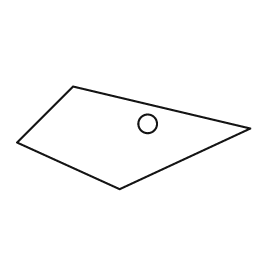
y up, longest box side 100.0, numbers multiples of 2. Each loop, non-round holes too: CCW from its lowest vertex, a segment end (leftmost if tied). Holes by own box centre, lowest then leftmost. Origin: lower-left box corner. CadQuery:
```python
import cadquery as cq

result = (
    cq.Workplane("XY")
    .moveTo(44.0, 0.0)
    .lineTo(100.0, 26.0)
    .lineTo(24.0, 44.0)
    .lineTo(0.0, 20.0)
    .close()
    .moveTo(56.0, 28.0)
    .circle(4.0)
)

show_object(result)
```